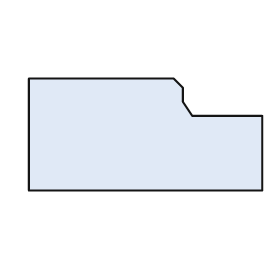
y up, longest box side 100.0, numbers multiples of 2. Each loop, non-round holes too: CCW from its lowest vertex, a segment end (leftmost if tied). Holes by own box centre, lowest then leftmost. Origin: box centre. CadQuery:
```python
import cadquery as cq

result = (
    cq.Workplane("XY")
    .moveTo(-50.0, -24.0)
    .lineTo(50.0, -24.0)
    .lineTo(50.0, 8.0)
    .lineTo(20.0, 8.0)
    .lineTo(16.0, 14.0)
    .lineTo(16.0, 20.0)
    .lineTo(12.0, 24.0)
    .lineTo(-50.0, 24.0)
    .close()
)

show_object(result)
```